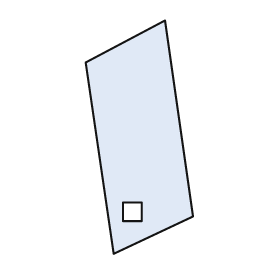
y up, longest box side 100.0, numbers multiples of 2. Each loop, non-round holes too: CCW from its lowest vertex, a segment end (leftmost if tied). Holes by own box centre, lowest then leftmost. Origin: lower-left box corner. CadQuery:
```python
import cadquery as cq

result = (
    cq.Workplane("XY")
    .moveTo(12.0, 0.0)
    .lineTo(46.0, 16.0)
    .lineTo(34.0, 100.0)
    .lineTo(0.0, 82.0)
    .close()
    .moveTo(16.0, 14.0)
    .lineTo(24.0, 14.0)
    .lineTo(24.0, 22.0)
    .lineTo(16.0, 22.0)
    .close()
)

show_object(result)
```